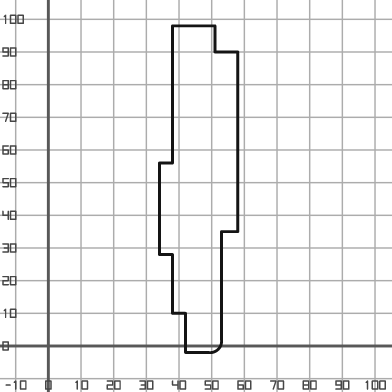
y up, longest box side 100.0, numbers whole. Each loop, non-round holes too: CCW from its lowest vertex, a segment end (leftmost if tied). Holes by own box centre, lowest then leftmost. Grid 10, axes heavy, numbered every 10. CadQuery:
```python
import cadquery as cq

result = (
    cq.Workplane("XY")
    .moveTo(42.0, -2.0)
    .lineTo(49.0, -2.0)
    .threePointArc((52.0, -1.0), (53.0, 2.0))
    .lineTo(53.0, 35.0)
    .lineTo(58.0, 35.0)
    .lineTo(58.0, 90.0)
    .lineTo(51.0, 90.0)
    .lineTo(51.0, 98.0)
    .lineTo(38.0, 98.0)
    .lineTo(38.0, 56.0)
    .lineTo(34.0, 56.0)
    .lineTo(34.0, 28.0)
    .lineTo(38.0, 28.0)
    .lineTo(38.0, 10.0)
    .lineTo(42.0, 10.0)
    .close()
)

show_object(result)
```